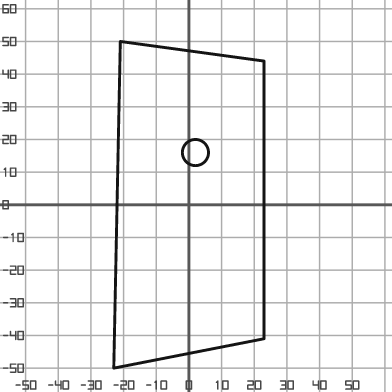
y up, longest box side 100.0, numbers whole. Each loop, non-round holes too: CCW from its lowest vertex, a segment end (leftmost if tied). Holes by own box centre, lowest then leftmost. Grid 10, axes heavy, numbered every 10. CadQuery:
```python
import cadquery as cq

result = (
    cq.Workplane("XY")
    .moveTo(-23.0, -50.0)
    .lineTo(23.0, -41.0)
    .lineTo(23.0, 44.0)
    .lineTo(-21.0, 50.0)
    .close()
    .moveTo(2.0, 16.0)
    .circle(4.0)
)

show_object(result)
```